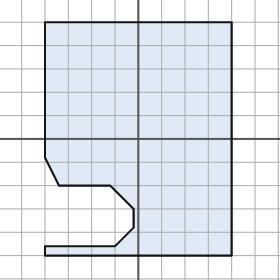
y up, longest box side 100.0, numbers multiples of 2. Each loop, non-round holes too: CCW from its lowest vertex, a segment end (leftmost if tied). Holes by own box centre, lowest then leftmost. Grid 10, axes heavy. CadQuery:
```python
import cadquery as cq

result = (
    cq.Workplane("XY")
    .moveTo(-40.0, -50.0)
    .lineTo(40.0, -50.0)
    .lineTo(40.0, 50.0)
    .lineTo(-40.0, 50.0)
    .lineTo(-40.0, -8.0)
    .lineTo(-34.0, -20.0)
    .lineTo(-12.0, -20.0)
    .lineTo(-2.0, -30.0)
    .lineTo(-2.0, -38.0)
    .lineTo(-10.0, -46.0)
    .lineTo(-40.0, -46.0)
    .close()
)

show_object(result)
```